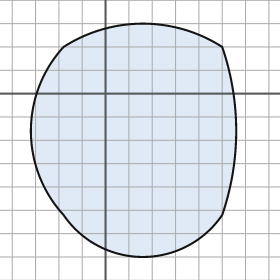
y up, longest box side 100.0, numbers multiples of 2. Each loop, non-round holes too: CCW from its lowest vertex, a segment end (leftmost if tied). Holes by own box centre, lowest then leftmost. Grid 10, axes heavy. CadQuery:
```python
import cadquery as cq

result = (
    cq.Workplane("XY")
    .moveTo(-18.0, -52.0)
    .threePointArc((16.0, -70.0), (50.0, -52.0))
    .threePointArc((56.0, -16.0), (50.0, 20.0))
    .threePointArc((16.0, 30.0), (-18.0, 20.0))
    .threePointArc((-32.0, -16.0), (-18.0, -52.0))
    .close()
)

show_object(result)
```